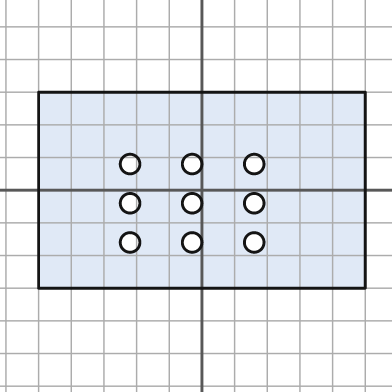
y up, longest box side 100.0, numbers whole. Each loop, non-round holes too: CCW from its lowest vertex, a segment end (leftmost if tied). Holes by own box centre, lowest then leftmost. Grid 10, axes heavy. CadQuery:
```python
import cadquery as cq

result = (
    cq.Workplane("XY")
    .moveTo(-50.0, -30.0)
    .lineTo(50.0, -30.0)
    .lineTo(50.0, 30.0)
    .lineTo(-50.0, 30.0)
    .close()
    .moveTo(-22.0, -16.0)
    .circle(3.0)
    .moveTo(-3.0, -16.0)
    .circle(3.0)
    .moveTo(16.0, -16.0)
    .circle(3.0)
    .moveTo(-22.0, -4.0)
    .circle(3.0)
    .moveTo(-3.0, -4.0)
    .circle(3.0)
    .moveTo(16.0, -4.0)
    .circle(3.0)
    .moveTo(-22.0, 8.0)
    .circle(3.0)
    .moveTo(-3.0, 8.0)
    .circle(3.0)
    .moveTo(16.0, 8.0)
    .circle(3.0)
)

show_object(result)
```